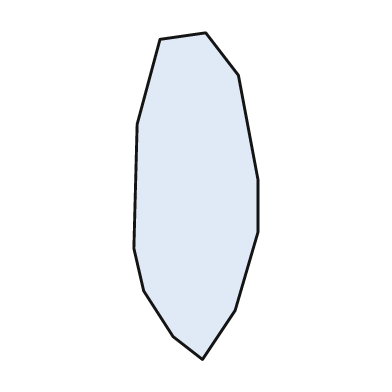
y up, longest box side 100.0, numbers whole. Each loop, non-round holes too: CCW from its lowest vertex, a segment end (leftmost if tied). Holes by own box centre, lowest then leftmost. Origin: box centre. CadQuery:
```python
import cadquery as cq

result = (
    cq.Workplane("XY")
    .moveTo(2.0, -50.0)
    .lineTo(12.0, -35.0)
    .lineTo(19.0, -11.0)
    .lineTo(19.0, 5.0)
    .lineTo(13.0, 37.0)
    .lineTo(3.0, 50.0)
    .lineTo(-11.0, 48.0)
    .lineTo(-18.0, 22.0)
    .lineTo(-19.0, -16.0)
    .lineTo(-16.0, -29.0)
    .lineTo(-7.0, -43.0)
    .close()
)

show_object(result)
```